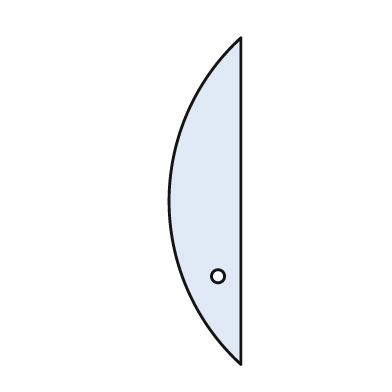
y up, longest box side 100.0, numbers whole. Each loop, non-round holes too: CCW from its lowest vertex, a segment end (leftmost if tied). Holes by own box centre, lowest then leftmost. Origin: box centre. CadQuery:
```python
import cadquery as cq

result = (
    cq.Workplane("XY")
    .moveTo(11.0, -50.0)
    .lineTo(11.0, 50.0)
    .threePointArc((-11.0, 0.0), (11.0, -50.0))
    .close()
    .moveTo(4.0, -23.0)
    .circle(2.0)
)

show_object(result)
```